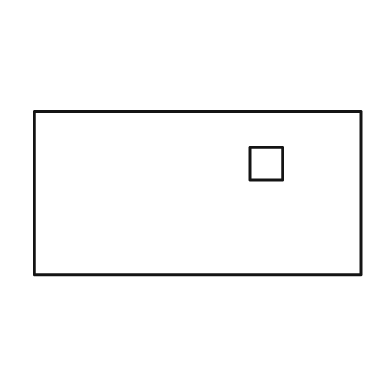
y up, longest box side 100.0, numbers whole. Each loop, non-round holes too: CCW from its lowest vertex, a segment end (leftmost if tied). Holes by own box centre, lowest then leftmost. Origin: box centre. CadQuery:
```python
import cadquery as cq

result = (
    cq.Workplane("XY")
    .moveTo(-50.0, -25.0)
    .lineTo(50.0, -25.0)
    .lineTo(50.0, 25.0)
    .lineTo(-50.0, 25.0)
    .close()
    .moveTo(16.0, 4.0)
    .lineTo(26.0, 4.0)
    .lineTo(26.0, 14.0)
    .lineTo(16.0, 14.0)
    .close()
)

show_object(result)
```